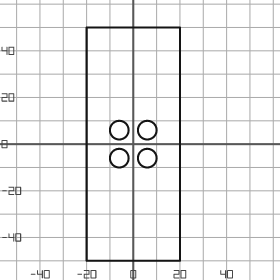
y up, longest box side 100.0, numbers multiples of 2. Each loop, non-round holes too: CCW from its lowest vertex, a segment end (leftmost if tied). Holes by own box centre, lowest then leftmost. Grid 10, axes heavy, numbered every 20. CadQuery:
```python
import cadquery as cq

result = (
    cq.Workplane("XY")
    .moveTo(-20.0, -50.0)
    .lineTo(20.0, -50.0)
    .lineTo(20.0, 50.0)
    .lineTo(-20.0, 50.0)
    .close()
    .moveTo(-6.0, -6.0)
    .circle(4.0)
    .moveTo(6.0, -6.0)
    .circle(4.0)
    .moveTo(-6.0, 6.0)
    .circle(4.0)
    .moveTo(6.0, 6.0)
    .circle(4.0)
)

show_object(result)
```